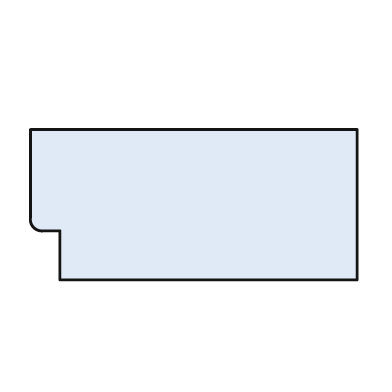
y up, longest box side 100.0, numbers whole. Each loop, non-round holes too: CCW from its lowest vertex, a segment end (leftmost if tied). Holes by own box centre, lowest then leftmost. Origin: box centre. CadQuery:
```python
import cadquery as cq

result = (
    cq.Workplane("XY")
    .moveTo(-41.0, -23.0)
    .lineTo(50.0, -23.0)
    .lineTo(50.0, 23.0)
    .lineTo(-50.0, 23.0)
    .lineTo(-50.0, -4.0)
    .threePointArc((-49.0, -7.0), (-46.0, -8.0))
    .lineTo(-41.0, -8.0)
    .close()
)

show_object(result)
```